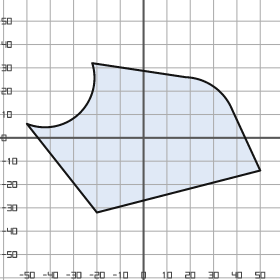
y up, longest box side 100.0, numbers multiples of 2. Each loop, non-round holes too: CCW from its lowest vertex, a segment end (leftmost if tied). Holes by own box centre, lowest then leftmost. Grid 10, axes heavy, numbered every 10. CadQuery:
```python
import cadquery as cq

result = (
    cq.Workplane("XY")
    .moveTo(-20.0, -32.0)
    .lineTo(50.0, -14.0)
    .lineTo(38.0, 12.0)
    .threePointArc((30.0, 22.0), (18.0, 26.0))
    .lineTo(-22.0, 32.0)
    .threePointArc((-28.0, 10.0), (-50.0, 6.0))
    .close()
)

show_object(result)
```